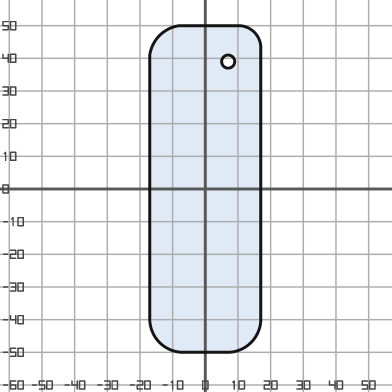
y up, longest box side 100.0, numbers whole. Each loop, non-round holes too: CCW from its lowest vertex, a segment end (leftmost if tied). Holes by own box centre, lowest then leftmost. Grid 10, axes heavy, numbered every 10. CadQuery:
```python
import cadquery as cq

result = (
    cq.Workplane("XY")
    .moveTo(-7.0, -50.0)
    .lineTo(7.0, -50.0)
    .threePointArc((14.0, -47.0), (17.0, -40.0))
    .lineTo(17.0, 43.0)
    .threePointArc((15.0, 48.0), (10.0, 50.0))
    .lineTo(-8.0, 50.0)
    .threePointArc((-14.0, 47.0), (-17.0, 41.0))
    .lineTo(-17.0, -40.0)
    .threePointArc((-14.0, -47.0), (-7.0, -50.0))
    .close()
    .moveTo(7.0, 39.0)
    .circle(2.0)
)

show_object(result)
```